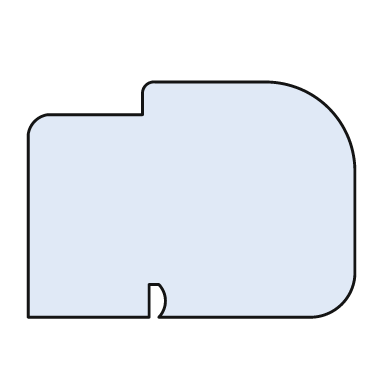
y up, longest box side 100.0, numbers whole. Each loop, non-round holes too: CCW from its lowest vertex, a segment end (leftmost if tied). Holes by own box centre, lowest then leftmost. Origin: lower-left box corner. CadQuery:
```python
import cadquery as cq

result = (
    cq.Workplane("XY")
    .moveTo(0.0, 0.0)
    .lineTo(37.0, 0.0)
    .lineTo(37.0, 10.0)
    .lineTo(40.0, 10.0)
    .threePointArc((42.0, 5.0), (40.0, 0.0))
    .lineTo(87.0, 0.0)
    .threePointArc((96.0, 4.0), (100.0, 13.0))
    .lineTo(100.0, 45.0)
    .threePointArc((92.0, 64.0), (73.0, 72.0))
    .lineTo(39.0, 72.0)
    .threePointArc((36.0, 71.0), (35.0, 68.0))
    .lineTo(35.0, 62.0)
    .lineTo(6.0, 62.0)
    .threePointArc((2.0, 60.0), (0.0, 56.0))
    .close()
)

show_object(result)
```